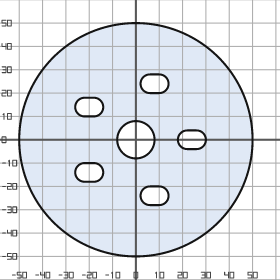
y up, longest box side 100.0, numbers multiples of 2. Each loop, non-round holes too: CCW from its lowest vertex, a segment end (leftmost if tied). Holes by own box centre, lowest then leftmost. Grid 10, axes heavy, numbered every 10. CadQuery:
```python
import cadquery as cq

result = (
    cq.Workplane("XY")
    .moveTo(0.0, 0.0)
    .circle(50.0)
    .moveTo(6.0, -28.0)
    .lineTo(10.0, -28.0)
    .threePointArc((14.0, -24.0), (10.0, -20.0))
    .lineTo(6.0, -20.0)
    .threePointArc((2.0, -24.0), (6.0, -28.0))
    .close()
    .moveTo(-22.0, -18.0)
    .lineTo(-18.0, -18.0)
    .threePointArc((-14.0, -14.0), (-18.0, -10.0))
    .lineTo(-22.0, -10.0)
    .threePointArc((-26.0, -14.0), (-22.0, -18.0))
    .close()
    .moveTo(0.0, 0.0)
    .circle(8.0)
    .moveTo(22.0, -4.0)
    .lineTo(26.0, -4.0)
    .threePointArc((30.0, 0.0), (26.0, 4.0))
    .lineTo(22.0, 4.0)
    .threePointArc((18.0, 0.0), (22.0, -4.0))
    .close()
    .moveTo(-22.0, 10.0)
    .lineTo(-18.0, 10.0)
    .threePointArc((-14.0, 14.0), (-18.0, 18.0))
    .lineTo(-22.0, 18.0)
    .threePointArc((-26.0, 14.0), (-22.0, 10.0))
    .close()
    .moveTo(6.0, 20.0)
    .lineTo(10.0, 20.0)
    .threePointArc((14.0, 24.0), (10.0, 28.0))
    .lineTo(6.0, 28.0)
    .threePointArc((2.0, 24.0), (6.0, 20.0))
    .close()
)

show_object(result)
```